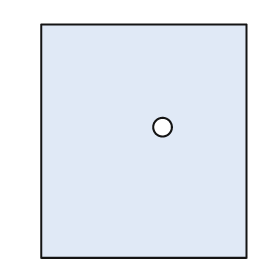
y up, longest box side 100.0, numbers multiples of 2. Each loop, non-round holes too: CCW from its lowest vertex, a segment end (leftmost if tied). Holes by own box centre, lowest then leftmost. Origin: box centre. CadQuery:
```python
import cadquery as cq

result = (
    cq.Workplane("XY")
    .moveTo(-44.0, -50.0)
    .lineTo(44.0, -50.0)
    .lineTo(44.0, 50.0)
    .lineTo(-44.0, 50.0)
    .close()
    .moveTo(8.0, 6.0)
    .circle(4.0)
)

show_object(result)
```